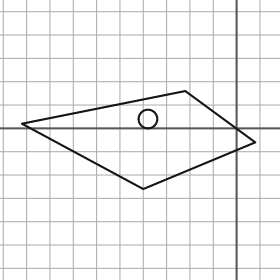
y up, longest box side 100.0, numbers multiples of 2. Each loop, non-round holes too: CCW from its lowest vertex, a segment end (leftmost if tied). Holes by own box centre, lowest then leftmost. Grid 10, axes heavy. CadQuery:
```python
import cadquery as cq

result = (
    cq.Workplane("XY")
    .moveTo(-40.0, -26.0)
    .lineTo(8.0, -6.0)
    .lineTo(-22.0, 16.0)
    .lineTo(-92.0, 2.0)
    .close()
    .moveTo(-38.0, 4.0)
    .circle(4.0)
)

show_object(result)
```